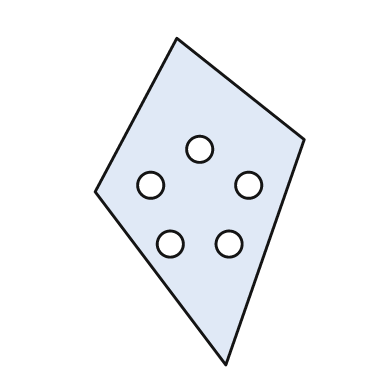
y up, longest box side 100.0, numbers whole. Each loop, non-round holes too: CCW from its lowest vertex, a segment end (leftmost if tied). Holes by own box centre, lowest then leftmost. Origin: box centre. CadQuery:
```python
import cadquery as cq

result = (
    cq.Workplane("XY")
    .moveTo(8.0, -50.0)
    .lineTo(32.0, 19.0)
    .lineTo(-7.0, 50.0)
    .lineTo(-32.0, 3.0)
    .close()
    .moveTo(-9.0, -13.0)
    .circle(4.0)
    .moveTo(9.0, -13.0)
    .circle(4.0)
    .moveTo(-15.0, 5.0)
    .circle(4.0)
    .moveTo(15.0, 5.0)
    .circle(4.0)
    .moveTo(0.0, 16.0)
    .circle(4.0)
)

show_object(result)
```